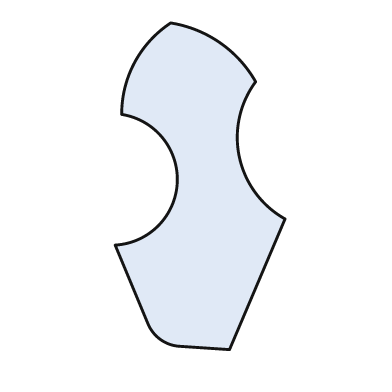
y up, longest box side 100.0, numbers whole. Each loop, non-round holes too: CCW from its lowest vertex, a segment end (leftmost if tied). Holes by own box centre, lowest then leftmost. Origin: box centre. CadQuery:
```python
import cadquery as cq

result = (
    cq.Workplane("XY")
    .moveTo(9.0, -50.0)
    .lineTo(26.0, -10.0)
    .threePointArc((12.0, 9.0), (17.0, 32.0))
    .threePointArc((6.0, 44.0), (-9.0, 50.0))
    .threePointArc((-20.0, 38.0), (-24.0, 22.0))
    .threePointArc((-7.0, 1.0), (-26.0, -18.0))
    .lineTo(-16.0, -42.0)
    .threePointArc((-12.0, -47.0), (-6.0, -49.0))
    .close()
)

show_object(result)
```